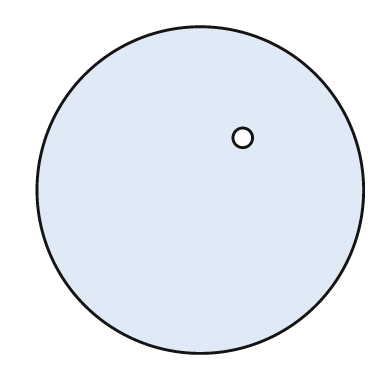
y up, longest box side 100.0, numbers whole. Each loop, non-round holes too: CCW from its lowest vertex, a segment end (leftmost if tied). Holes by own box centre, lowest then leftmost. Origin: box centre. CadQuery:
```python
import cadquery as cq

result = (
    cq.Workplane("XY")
    .moveTo(0.0, 0.0)
    .circle(50.0)
    .moveTo(13.0, 16.0)
    .circle(3.0)
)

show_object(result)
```